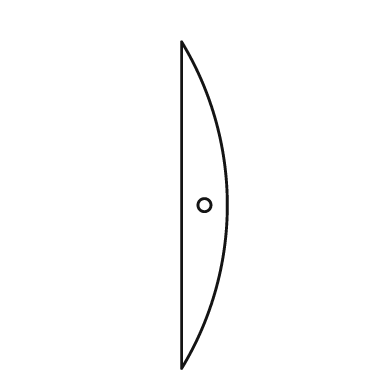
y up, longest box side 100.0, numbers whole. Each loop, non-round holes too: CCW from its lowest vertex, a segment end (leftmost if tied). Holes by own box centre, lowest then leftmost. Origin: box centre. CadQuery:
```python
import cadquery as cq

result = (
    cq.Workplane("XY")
    .moveTo(-7.0, -50.0)
    .threePointArc((7.0, 0.0), (-7.0, 50.0))
    .close()
    .moveTo(0.0, 0.0)
    .circle(2.0)
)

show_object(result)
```